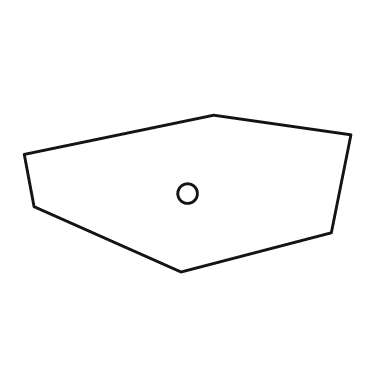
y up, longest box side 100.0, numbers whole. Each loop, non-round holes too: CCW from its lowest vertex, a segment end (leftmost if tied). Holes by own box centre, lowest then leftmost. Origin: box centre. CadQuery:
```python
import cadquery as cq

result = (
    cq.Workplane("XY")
    .moveTo(-2.0, -24.0)
    .lineTo(44.0, -12.0)
    .lineTo(50.0, 18.0)
    .lineTo(8.0, 24.0)
    .lineTo(-50.0, 12.0)
    .lineTo(-47.0, -4.0)
    .close()
    .moveTo(0.0, 0.0)
    .circle(3.0)
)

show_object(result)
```